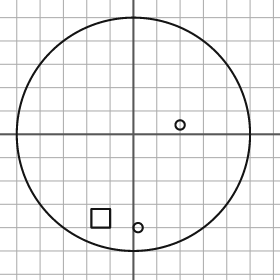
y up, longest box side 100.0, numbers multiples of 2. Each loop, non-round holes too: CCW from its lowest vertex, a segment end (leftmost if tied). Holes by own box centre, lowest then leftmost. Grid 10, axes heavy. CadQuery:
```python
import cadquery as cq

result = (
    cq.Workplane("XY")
    .moveTo(0.0, 0.0)
    .circle(50.0)
    .moveTo(2.0, -40.0)
    .circle(2.0)
    .moveTo(-18.0, -40.0)
    .lineTo(-10.0, -40.0)
    .lineTo(-10.0, -32.0)
    .lineTo(-18.0, -32.0)
    .close()
    .moveTo(20.0, 4.0)
    .circle(2.0)
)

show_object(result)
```